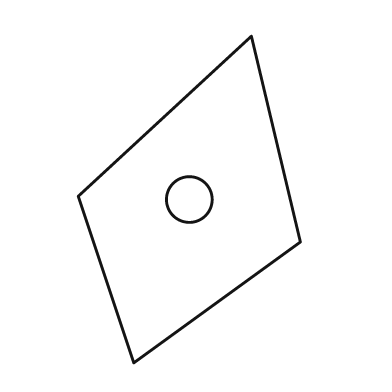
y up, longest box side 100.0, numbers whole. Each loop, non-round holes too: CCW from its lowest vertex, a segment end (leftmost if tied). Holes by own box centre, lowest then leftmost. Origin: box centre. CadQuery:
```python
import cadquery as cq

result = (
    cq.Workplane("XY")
    .moveTo(-17.0, -50.0)
    .lineTo(34.0, -13.0)
    .lineTo(19.0, 50.0)
    .lineTo(-34.0, 1.0)
    .close()
    .moveTo(0.0, 0.0)
    .circle(7.0)
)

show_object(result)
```